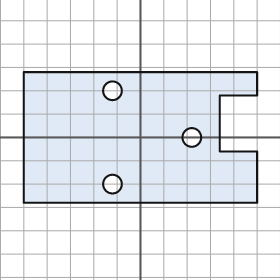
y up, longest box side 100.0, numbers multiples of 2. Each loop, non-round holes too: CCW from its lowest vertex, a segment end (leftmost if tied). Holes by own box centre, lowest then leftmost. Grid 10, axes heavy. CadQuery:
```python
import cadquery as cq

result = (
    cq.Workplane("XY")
    .moveTo(-50.0, -28.0)
    .lineTo(50.0, -28.0)
    .lineTo(50.0, -6.0)
    .lineTo(34.0, -6.0)
    .lineTo(34.0, 18.0)
    .lineTo(50.0, 18.0)
    .lineTo(50.0, 28.0)
    .lineTo(-50.0, 28.0)
    .close()
    .moveTo(-12.0, -20.0)
    .circle(4.0)
    .moveTo(22.0, 0.0)
    .circle(4.0)
    .moveTo(-12.0, 20.0)
    .circle(4.0)
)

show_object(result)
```